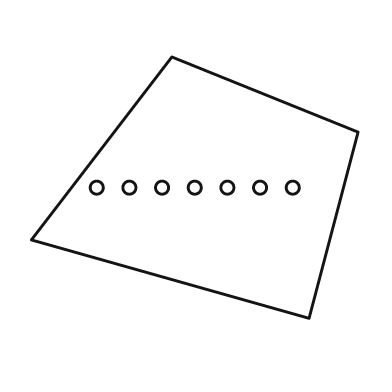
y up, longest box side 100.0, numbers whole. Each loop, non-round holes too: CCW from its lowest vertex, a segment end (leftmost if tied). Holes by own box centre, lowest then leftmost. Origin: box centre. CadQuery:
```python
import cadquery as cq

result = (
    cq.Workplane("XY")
    .moveTo(35.0, -40.0)
    .lineTo(50.0, 17.0)
    .lineTo(-7.0, 40.0)
    .lineTo(-50.0, -16.0)
    .close()
    .moveTo(-30.0, 0.0)
    .circle(2.0)
    .moveTo(-20.0, 0.0)
    .circle(2.0)
    .moveTo(-10.0, 0.0)
    .circle(2.0)
    .moveTo(0.0, 0.0)
    .circle(2.0)
    .moveTo(10.0, 0.0)
    .circle(2.0)
    .moveTo(20.0, 0.0)
    .circle(2.0)
    .moveTo(30.0, 0.0)
    .circle(2.0)
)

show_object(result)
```